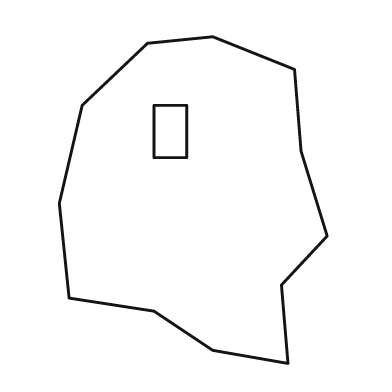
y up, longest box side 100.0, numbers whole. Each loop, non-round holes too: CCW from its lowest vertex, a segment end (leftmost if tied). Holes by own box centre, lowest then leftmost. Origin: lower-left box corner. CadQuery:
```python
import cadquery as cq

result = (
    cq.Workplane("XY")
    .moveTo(70.0, 0.0)
    .lineTo(68.0, 24.0)
    .lineTo(82.0, 39.0)
    .lineTo(74.0, 65.0)
    .lineTo(72.0, 90.0)
    .lineTo(47.0, 100.0)
    .lineTo(27.0, 98.0)
    .lineTo(7.0, 79.0)
    .lineTo(0.0, 49.0)
    .lineTo(3.0, 20.0)
    .lineTo(29.0, 16.0)
    .lineTo(47.0, 4.0)
    .close()
    .moveTo(29.0, 63.0)
    .lineTo(39.0, 63.0)
    .lineTo(39.0, 79.0)
    .lineTo(29.0, 79.0)
    .close()
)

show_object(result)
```